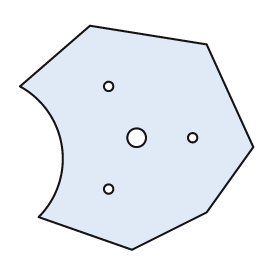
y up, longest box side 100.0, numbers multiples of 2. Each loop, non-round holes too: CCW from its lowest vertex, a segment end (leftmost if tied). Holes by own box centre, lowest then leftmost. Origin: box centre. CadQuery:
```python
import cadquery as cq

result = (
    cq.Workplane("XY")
    .moveTo(-2.0, -48.0)
    .lineTo(30.0, -32.0)
    .lineTo(50.0, -4.0)
    .lineTo(30.0, 40.0)
    .lineTo(-20.0, 48.0)
    .lineTo(-50.0, 22.0)
    .threePointArc((-32.0, -4.0), (-42.0, -34.0))
    .close()
    .moveTo(-12.0, -22.0)
    .circle(2.0)
    .moveTo(0.0, 0.0)
    .circle(4.0)
    .moveTo(24.0, 0.0)
    .circle(2.0)
    .moveTo(-12.0, 22.0)
    .circle(2.0)
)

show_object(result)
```